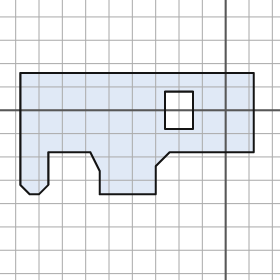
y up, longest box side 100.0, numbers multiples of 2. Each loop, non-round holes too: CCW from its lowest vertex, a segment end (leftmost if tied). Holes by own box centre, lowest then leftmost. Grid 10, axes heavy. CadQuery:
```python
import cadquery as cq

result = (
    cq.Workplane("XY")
    .moveTo(-84.0, -36.0)
    .lineTo(-80.0, -36.0)
    .lineTo(-76.0, -32.0)
    .lineTo(-76.0, -18.0)
    .lineTo(-58.0, -18.0)
    .lineTo(-54.0, -26.0)
    .lineTo(-54.0, -36.0)
    .lineTo(-30.0, -36.0)
    .lineTo(-30.0, -24.0)
    .lineTo(-24.0, -18.0)
    .lineTo(12.0, -18.0)
    .lineTo(12.0, 16.0)
    .lineTo(-88.0, 16.0)
    .lineTo(-88.0, -32.0)
    .close()
    .moveTo(-26.0, -8.0)
    .lineTo(-14.0, -8.0)
    .lineTo(-14.0, 8.0)
    .lineTo(-26.0, 8.0)
    .close()
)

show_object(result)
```